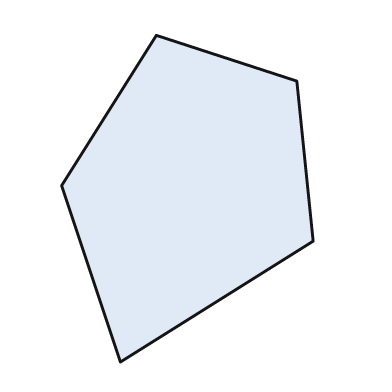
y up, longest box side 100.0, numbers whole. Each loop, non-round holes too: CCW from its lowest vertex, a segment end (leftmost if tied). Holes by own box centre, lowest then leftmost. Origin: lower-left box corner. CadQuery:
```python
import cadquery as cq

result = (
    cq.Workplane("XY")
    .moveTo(18.0, 0.0)
    .lineTo(77.0, 37.0)
    .lineTo(72.0, 86.0)
    .lineTo(29.0, 100.0)
    .lineTo(0.0, 54.0)
    .close()
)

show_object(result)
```